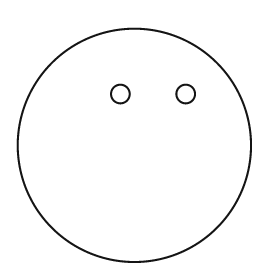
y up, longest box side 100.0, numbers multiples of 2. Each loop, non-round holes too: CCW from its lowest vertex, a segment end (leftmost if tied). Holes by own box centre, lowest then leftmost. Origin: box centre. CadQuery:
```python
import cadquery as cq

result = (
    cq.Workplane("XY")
    .moveTo(0.0, 0.0)
    .circle(50.0)
    .moveTo(-6.0, 22.0)
    .circle(4.0)
    .moveTo(22.0, 22.0)
    .circle(4.0)
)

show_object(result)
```